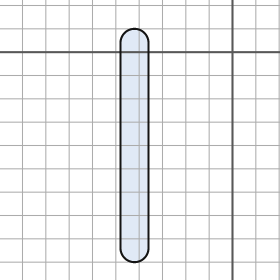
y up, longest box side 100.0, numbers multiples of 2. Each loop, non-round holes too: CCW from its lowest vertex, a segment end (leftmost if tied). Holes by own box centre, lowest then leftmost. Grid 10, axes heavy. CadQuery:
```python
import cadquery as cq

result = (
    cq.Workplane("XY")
    .moveTo(-48.0, -84.0)
    .threePointArc((-42.0, -90.0), (-36.0, -84.0))
    .lineTo(-36.0, 4.0)
    .threePointArc((-42.0, 10.0), (-48.0, 4.0))
    .close()
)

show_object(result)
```